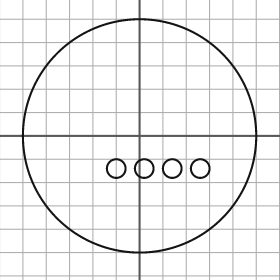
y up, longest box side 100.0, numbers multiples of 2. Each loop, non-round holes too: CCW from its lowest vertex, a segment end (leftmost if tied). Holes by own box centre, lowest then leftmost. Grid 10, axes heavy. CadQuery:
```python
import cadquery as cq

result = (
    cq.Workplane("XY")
    .moveTo(0.0, 0.0)
    .circle(50.0)
    .moveTo(-10.0, -14.0)
    .circle(4.0)
    .moveTo(2.0, -14.0)
    .circle(4.0)
    .moveTo(14.0, -14.0)
    .circle(4.0)
    .moveTo(26.0, -14.0)
    .circle(4.0)
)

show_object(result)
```